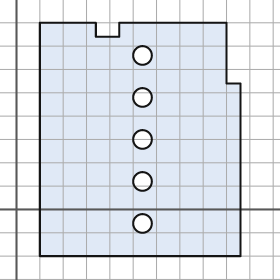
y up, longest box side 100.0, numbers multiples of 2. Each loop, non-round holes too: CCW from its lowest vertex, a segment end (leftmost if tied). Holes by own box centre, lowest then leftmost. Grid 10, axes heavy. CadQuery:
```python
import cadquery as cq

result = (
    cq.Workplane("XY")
    .moveTo(10.0, -20.0)
    .lineTo(96.0, -20.0)
    .lineTo(96.0, 54.0)
    .lineTo(90.0, 54.0)
    .lineTo(90.0, 80.0)
    .lineTo(44.0, 80.0)
    .lineTo(44.0, 74.0)
    .lineTo(34.0, 74.0)
    .lineTo(34.0, 80.0)
    .lineTo(10.0, 80.0)
    .close()
    .moveTo(54.0, -6.0)
    .circle(4.0)
    .moveTo(54.0, 12.0)
    .circle(4.0)
    .moveTo(54.0, 30.0)
    .circle(4.0)
    .moveTo(54.0, 48.0)
    .circle(4.0)
    .moveTo(54.0, 66.0)
    .circle(4.0)
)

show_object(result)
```